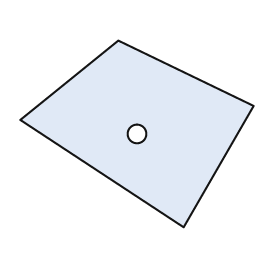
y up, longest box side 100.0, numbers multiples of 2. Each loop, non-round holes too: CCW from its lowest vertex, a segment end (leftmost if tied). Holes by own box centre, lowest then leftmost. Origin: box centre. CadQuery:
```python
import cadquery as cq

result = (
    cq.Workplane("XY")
    .moveTo(20.0, -40.0)
    .lineTo(50.0, 12.0)
    .lineTo(-8.0, 40.0)
    .lineTo(-50.0, 6.0)
    .close()
    .moveTo(0.0, 0.0)
    .circle(4.0)
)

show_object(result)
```